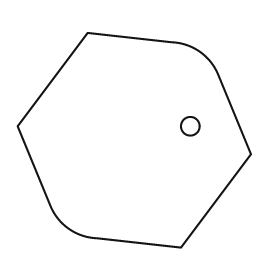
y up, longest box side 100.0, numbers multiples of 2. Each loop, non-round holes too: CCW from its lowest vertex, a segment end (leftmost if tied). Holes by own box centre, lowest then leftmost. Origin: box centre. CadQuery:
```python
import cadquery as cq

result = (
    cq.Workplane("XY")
    .moveTo(20.0, -46.0)
    .lineTo(50.0, -6.0)
    .lineTo(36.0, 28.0)
    .threePointArc((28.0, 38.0), (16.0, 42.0))
    .lineTo(-20.0, 46.0)
    .lineTo(-50.0, 6.0)
    .lineTo(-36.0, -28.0)
    .threePointArc((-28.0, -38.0), (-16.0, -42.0))
    .close()
    .moveTo(24.0, 6.0)
    .circle(4.0)
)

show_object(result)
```